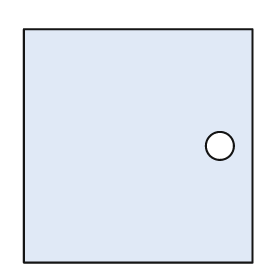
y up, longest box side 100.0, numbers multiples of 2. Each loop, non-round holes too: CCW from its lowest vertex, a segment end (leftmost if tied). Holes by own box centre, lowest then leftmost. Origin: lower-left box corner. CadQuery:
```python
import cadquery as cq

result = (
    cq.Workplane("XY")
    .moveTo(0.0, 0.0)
    .lineTo(98.0, 0.0)
    .lineTo(98.0, 100.0)
    .lineTo(0.0, 100.0)
    .close()
    .moveTo(84.0, 50.0)
    .circle(6.0)
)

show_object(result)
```